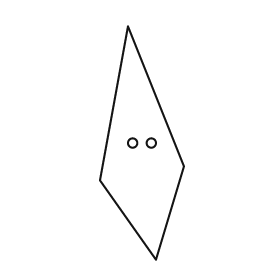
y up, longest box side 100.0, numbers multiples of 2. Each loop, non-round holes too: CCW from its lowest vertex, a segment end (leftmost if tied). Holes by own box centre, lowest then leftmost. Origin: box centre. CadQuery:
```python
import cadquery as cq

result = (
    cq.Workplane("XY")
    .moveTo(6.0, -50.0)
    .lineTo(18.0, -10.0)
    .lineTo(-6.0, 50.0)
    .lineTo(-18.0, -16.0)
    .close()
    .moveTo(-4.0, 0.0)
    .circle(2.0)
    .moveTo(4.0, 0.0)
    .circle(2.0)
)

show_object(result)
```